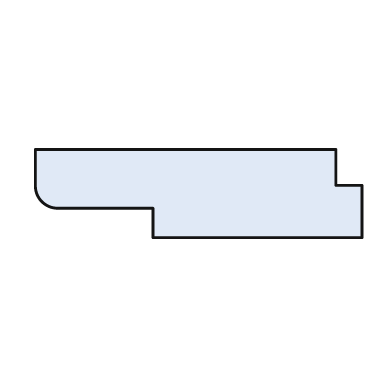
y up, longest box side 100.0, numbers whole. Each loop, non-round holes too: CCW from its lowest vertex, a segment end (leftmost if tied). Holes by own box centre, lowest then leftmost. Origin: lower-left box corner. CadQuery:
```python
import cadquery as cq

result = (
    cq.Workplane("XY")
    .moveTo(36.0, 0.0)
    .lineTo(100.0, 0.0)
    .lineTo(100.0, 16.0)
    .lineTo(92.0, 16.0)
    .lineTo(92.0, 27.0)
    .lineTo(0.0, 27.0)
    .lineTo(0.0, 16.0)
    .threePointArc((2.0, 11.0), (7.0, 9.0))
    .lineTo(36.0, 9.0)
    .close()
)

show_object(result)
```